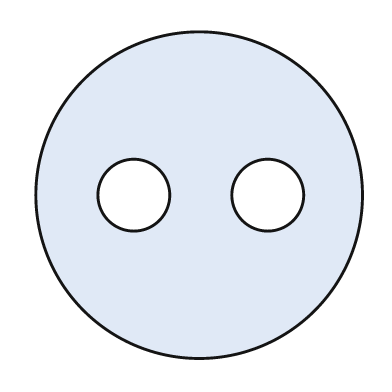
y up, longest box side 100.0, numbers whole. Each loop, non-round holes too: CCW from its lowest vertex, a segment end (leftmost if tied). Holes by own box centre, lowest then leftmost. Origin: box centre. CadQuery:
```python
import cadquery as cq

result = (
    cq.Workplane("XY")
    .moveTo(0.0, 0.0)
    .circle(50.0)
    .moveTo(-20.0, 0.0)
    .circle(11.0)
    .moveTo(21.0, 0.0)
    .circle(11.0)
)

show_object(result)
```